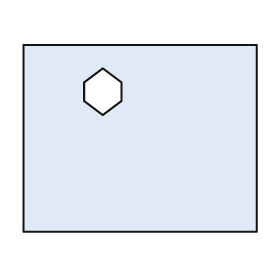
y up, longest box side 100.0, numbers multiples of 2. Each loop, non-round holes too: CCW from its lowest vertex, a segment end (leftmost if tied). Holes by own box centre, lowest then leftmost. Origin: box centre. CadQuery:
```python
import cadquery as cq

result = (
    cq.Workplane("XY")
    .moveTo(-50.0, -40.0)
    .lineTo(50.0, -40.0)
    .lineTo(50.0, 40.0)
    .lineTo(-50.0, 40.0)
    .close()
    .moveTo(-16.0, 10.0)
    .lineTo(-8.0, 16.0)
    .lineTo(-8.0, 24.0)
    .lineTo(-16.0, 30.0)
    .lineTo(-24.0, 24.0)
    .lineTo(-24.0, 16.0)
    .close()
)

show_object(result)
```